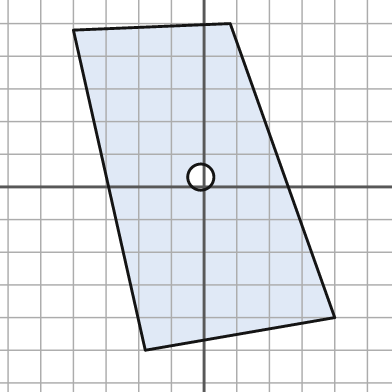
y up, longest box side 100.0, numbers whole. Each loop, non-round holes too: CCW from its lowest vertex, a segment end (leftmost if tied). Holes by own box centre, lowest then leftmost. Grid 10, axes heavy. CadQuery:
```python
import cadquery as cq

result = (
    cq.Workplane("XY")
    .moveTo(-18.0, -50.0)
    .lineTo(40.0, -40.0)
    .lineTo(8.0, 50.0)
    .lineTo(-40.0, 48.0)
    .close()
    .moveTo(-1.0, 3.0)
    .circle(4.0)
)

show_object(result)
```